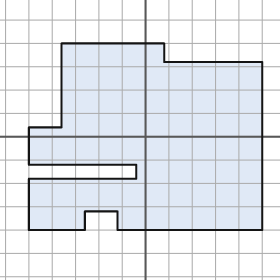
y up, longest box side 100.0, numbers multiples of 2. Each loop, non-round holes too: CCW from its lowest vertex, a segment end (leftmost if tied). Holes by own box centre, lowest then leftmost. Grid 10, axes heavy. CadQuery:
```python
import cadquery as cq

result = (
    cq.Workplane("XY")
    .moveTo(-50.0, -40.0)
    .lineTo(-26.0, -40.0)
    .lineTo(-26.0, -32.0)
    .lineTo(-12.0, -32.0)
    .lineTo(-12.0, -40.0)
    .lineTo(50.0, -40.0)
    .lineTo(50.0, 32.0)
    .lineTo(8.0, 32.0)
    .lineTo(8.0, 40.0)
    .lineTo(-36.0, 40.0)
    .lineTo(-36.0, 4.0)
    .lineTo(-50.0, 4.0)
    .lineTo(-50.0, -12.0)
    .lineTo(-4.0, -12.0)
    .lineTo(-4.0, -18.0)
    .lineTo(-50.0, -18.0)
    .close()
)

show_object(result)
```